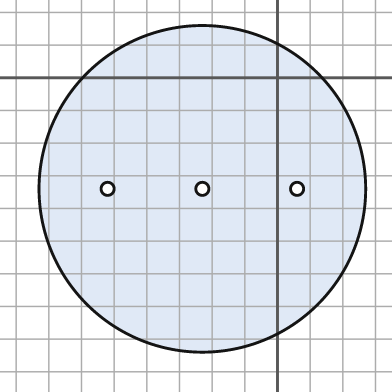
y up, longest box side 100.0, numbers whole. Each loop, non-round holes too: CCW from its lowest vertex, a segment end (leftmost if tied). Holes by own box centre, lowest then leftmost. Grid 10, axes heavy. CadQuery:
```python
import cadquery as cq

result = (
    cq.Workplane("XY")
    .moveTo(-23.0, -34.0)
    .circle(50.0)
    .moveTo(-52.0, -34.0)
    .circle(2.0)
    .moveTo(-23.0, -34.0)
    .circle(2.0)
    .moveTo(6.0, -34.0)
    .circle(2.0)
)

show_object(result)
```